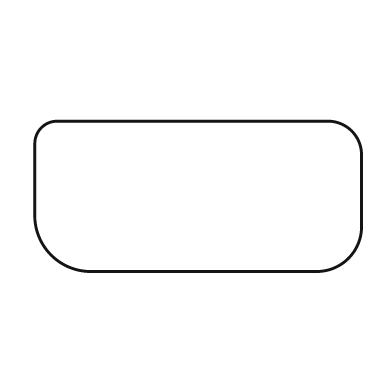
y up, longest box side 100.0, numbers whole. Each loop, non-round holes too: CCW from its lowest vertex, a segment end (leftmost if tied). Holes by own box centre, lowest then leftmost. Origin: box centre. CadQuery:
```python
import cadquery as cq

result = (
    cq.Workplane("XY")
    .moveTo(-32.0, -23.0)
    .lineTo(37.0, -23.0)
    .threePointArc((46.0, -19.0), (50.0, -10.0))
    .lineTo(50.0, 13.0)
    .threePointArc((47.0, 20.0), (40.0, 23.0))
    .lineTo(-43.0, 23.0)
    .threePointArc((-48.0, 21.0), (-50.0, 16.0))
    .lineTo(-50.0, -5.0)
    .threePointArc((-45.0, -18.0), (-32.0, -23.0))
    .close()
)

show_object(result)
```